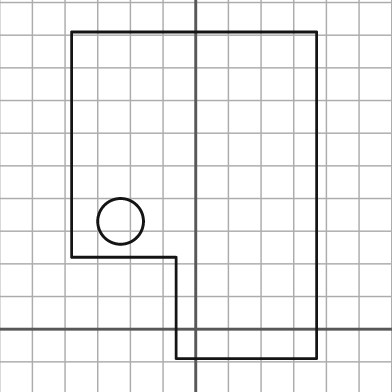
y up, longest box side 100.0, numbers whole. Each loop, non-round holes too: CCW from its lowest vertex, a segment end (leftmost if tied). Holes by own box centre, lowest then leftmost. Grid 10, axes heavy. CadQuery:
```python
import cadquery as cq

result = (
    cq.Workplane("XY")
    .moveTo(-6.0, -9.0)
    .lineTo(37.0, -9.0)
    .lineTo(37.0, 91.0)
    .lineTo(-38.0, 91.0)
    .lineTo(-38.0, 22.0)
    .lineTo(-6.0, 22.0)
    .close()
    .moveTo(-23.0, 33.0)
    .circle(7.0)
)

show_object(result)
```